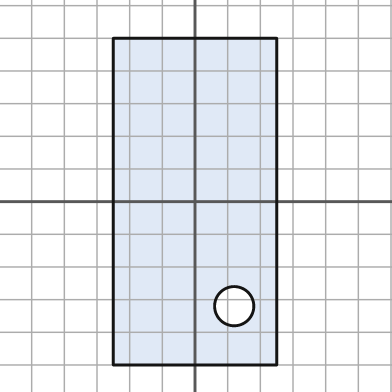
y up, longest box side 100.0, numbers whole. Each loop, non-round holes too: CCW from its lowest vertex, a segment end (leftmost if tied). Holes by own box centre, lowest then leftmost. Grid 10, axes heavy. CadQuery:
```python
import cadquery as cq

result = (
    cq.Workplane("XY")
    .moveTo(-25.0, -50.0)
    .lineTo(25.0, -50.0)
    .lineTo(25.0, 50.0)
    .lineTo(-25.0, 50.0)
    .close()
    .moveTo(12.0, -32.0)
    .circle(6.0)
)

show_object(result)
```